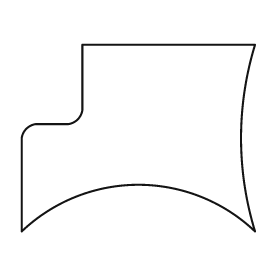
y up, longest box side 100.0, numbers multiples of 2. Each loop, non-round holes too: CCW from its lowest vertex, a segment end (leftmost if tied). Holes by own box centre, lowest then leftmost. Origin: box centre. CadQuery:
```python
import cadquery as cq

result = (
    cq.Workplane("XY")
    .moveTo(-50.0, -40.0)
    .threePointArc((0.0, -20.0), (50.0, -40.0))
    .threePointArc((44.0, 0.0), (50.0, 40.0))
    .lineTo(-24.0, 40.0)
    .lineTo(-24.0, 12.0)
    .threePointArc((-26.0, 8.0), (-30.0, 6.0))
    .lineTo(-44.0, 6.0)
    .threePointArc((-48.0, 4.0), (-50.0, 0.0))
    .close()
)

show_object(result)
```